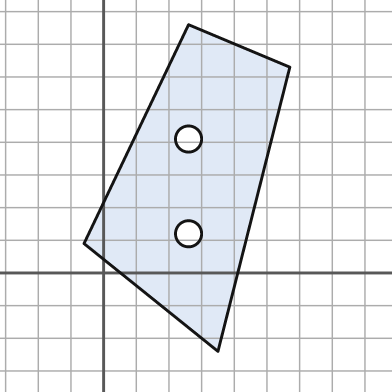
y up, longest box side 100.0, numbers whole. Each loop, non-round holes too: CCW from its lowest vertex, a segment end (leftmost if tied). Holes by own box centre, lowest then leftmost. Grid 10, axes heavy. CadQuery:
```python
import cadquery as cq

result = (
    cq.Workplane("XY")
    .moveTo(35.0, -24.0)
    .lineTo(57.0, 63.0)
    .lineTo(26.0, 76.0)
    .lineTo(-6.0, 9.0)
    .close()
    .moveTo(26.0, 12.0)
    .circle(4.0)
    .moveTo(26.0, 41.0)
    .circle(4.0)
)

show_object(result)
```